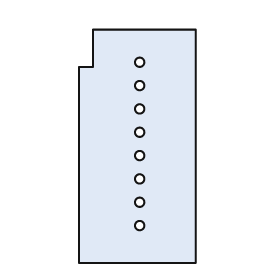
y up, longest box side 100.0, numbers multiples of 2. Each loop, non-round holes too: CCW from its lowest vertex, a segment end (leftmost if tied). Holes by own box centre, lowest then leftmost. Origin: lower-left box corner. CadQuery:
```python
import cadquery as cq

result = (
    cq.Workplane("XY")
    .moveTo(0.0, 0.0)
    .lineTo(50.0, 0.0)
    .lineTo(50.0, 100.0)
    .lineTo(6.0, 100.0)
    .lineTo(6.0, 84.0)
    .lineTo(0.0, 84.0)
    .close()
    .moveTo(26.0, 16.0)
    .circle(2.0)
    .moveTo(26.0, 26.0)
    .circle(2.0)
    .moveTo(26.0, 36.0)
    .circle(2.0)
    .moveTo(26.0, 46.0)
    .circle(2.0)
    .moveTo(26.0, 56.0)
    .circle(2.0)
    .moveTo(26.0, 66.0)
    .circle(2.0)
    .moveTo(26.0, 76.0)
    .circle(2.0)
    .moveTo(26.0, 86.0)
    .circle(2.0)
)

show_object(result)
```